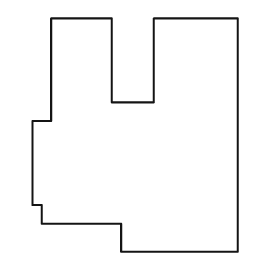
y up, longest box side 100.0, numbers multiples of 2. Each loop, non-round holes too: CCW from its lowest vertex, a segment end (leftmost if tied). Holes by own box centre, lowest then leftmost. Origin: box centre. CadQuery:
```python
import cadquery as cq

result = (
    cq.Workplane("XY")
    .moveTo(-6.0, -50.0)
    .lineTo(44.0, -50.0)
    .lineTo(44.0, 50.0)
    .lineTo(8.0, 50.0)
    .lineTo(8.0, 14.0)
    .lineTo(-10.0, 14.0)
    .lineTo(-10.0, 50.0)
    .lineTo(-36.0, 50.0)
    .lineTo(-36.0, 6.0)
    .lineTo(-44.0, 6.0)
    .lineTo(-44.0, -30.0)
    .lineTo(-40.0, -30.0)
    .lineTo(-40.0, -38.0)
    .lineTo(-6.0, -38.0)
    .close()
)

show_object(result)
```